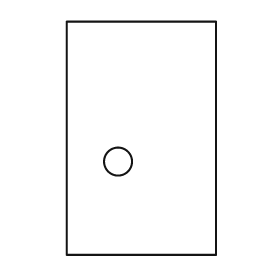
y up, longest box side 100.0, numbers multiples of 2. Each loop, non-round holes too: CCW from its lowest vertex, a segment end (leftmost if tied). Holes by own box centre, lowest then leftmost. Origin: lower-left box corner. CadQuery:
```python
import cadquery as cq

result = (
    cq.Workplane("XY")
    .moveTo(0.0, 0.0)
    .lineTo(64.0, 0.0)
    .lineTo(64.0, 100.0)
    .lineTo(0.0, 100.0)
    .close()
    .moveTo(22.0, 40.0)
    .circle(6.0)
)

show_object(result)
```